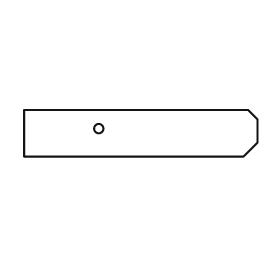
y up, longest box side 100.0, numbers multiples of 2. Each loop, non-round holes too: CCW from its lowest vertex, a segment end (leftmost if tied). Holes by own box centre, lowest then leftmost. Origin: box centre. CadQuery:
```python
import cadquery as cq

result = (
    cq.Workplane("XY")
    .moveTo(-50.0, -10.0)
    .lineTo(44.0, -10.0)
    .lineTo(50.0, -4.0)
    .lineTo(50.0, 6.0)
    .lineTo(46.0, 10.0)
    .lineTo(-50.0, 10.0)
    .close()
    .moveTo(-18.0, 2.0)
    .circle(2.0)
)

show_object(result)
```